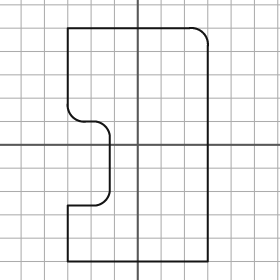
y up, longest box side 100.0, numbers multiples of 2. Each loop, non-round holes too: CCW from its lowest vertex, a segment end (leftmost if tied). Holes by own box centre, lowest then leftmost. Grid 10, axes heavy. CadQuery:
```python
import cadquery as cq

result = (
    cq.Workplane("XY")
    .moveTo(-30.0, -50.0)
    .lineTo(30.0, -50.0)
    .lineTo(30.0, 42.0)
    .threePointArc((28.0, 48.0), (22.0, 50.0))
    .lineTo(-30.0, 50.0)
    .lineTo(-30.0, 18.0)
    .threePointArc((-28.0, 12.0), (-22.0, 10.0))
    .lineTo(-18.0, 10.0)
    .threePointArc((-14.0, 8.0), (-12.0, 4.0))
    .lineTo(-12.0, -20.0)
    .threePointArc((-14.0, -24.0), (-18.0, -26.0))
    .lineTo(-30.0, -26.0)
    .close()
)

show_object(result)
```